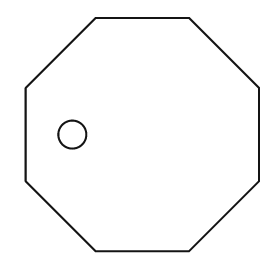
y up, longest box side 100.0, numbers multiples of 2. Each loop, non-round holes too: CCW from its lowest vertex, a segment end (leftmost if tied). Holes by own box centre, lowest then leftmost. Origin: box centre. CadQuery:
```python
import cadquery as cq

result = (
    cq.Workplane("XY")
    .moveTo(-20.0, -50.0)
    .lineTo(20.0, -50.0)
    .lineTo(50.0, -20.0)
    .lineTo(50.0, 20.0)
    .lineTo(20.0, 50.0)
    .lineTo(-20.0, 50.0)
    .lineTo(-50.0, 20.0)
    .lineTo(-50.0, -20.0)
    .close()
    .moveTo(-30.0, 0.0)
    .circle(6.0)
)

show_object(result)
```